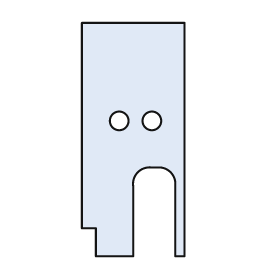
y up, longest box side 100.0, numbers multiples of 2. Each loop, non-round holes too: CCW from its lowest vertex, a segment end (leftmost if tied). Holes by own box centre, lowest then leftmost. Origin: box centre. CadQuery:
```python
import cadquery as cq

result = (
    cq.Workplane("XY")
    .moveTo(-16.0, -50.0)
    .lineTo(0.0, -50.0)
    .lineTo(0.0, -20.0)
    .threePointArc((2.0, -14.0), (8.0, -12.0))
    .lineTo(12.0, -12.0)
    .threePointArc((16.0, -14.0), (18.0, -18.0))
    .lineTo(18.0, -50.0)
    .lineTo(22.0, -50.0)
    .lineTo(22.0, 50.0)
    .lineTo(-22.0, 50.0)
    .lineTo(-22.0, -38.0)
    .lineTo(-16.0, -38.0)
    .close()
    .moveTo(-6.0, 8.0)
    .circle(4.0)
    .moveTo(8.0, 8.0)
    .circle(4.0)
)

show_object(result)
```